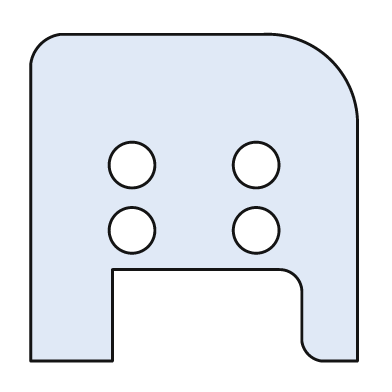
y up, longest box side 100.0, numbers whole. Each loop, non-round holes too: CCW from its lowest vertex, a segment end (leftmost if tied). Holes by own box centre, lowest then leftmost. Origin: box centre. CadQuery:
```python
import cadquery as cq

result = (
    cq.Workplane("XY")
    .moveTo(-50.0, -50.0)
    .lineTo(-25.0, -50.0)
    .lineTo(-25.0, -22.0)
    .lineTo(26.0, -22.0)
    .threePointArc((31.0, -24.0), (33.0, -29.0))
    .lineTo(33.0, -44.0)
    .threePointArc((35.0, -48.0), (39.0, -50.0))
    .lineTo(50.0, -50.0)
    .lineTo(50.0, 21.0)
    .threePointArc((42.0, 42.0), (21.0, 50.0))
    .lineTo(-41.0, 50.0)
    .threePointArc((-47.0, 47.0), (-50.0, 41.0))
    .close()
    .moveTo(-19.0, -10.0)
    .circle(7.0)
    .moveTo(19.0, -10.0)
    .circle(7.0)
    .moveTo(-19.0, 10.0)
    .circle(7.0)
    .moveTo(19.0, 10.0)
    .circle(7.0)
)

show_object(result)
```